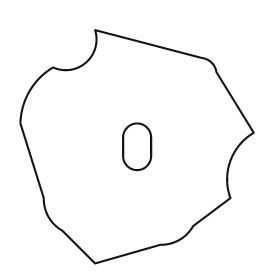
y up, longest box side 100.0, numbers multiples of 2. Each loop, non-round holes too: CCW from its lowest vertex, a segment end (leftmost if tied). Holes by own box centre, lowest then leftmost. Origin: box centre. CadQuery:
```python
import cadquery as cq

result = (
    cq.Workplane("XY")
    .moveTo(-18.0, -50.0)
    .lineTo(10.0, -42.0)
    .threePointArc((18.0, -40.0), (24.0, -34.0))
    .lineTo(40.0, -22.0)
    .threePointArc((40.0, -6.0), (50.0, 6.0))
    .lineTo(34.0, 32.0)
    .threePointArc((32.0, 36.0), (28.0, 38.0))
    .lineTo(-18.0, 50.0)
    .threePointArc((-22.0, 36.0), (-36.0, 34.0))
    .threePointArc((-46.0, 24.0), (-50.0, 10.0))
    .lineTo(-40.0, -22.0)
    .threePointArc((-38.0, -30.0), (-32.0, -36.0))
    .close()
    .moveTo(-6.0, -4.0)
    .threePointArc((0.0, -10.0), (6.0, -4.0))
    .lineTo(6.0, 4.0)
    .threePointArc((0.0, 10.0), (-6.0, 4.0))
    .close()
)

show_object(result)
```